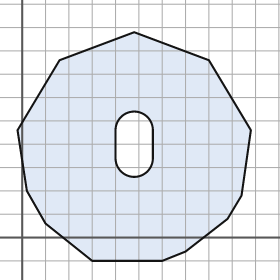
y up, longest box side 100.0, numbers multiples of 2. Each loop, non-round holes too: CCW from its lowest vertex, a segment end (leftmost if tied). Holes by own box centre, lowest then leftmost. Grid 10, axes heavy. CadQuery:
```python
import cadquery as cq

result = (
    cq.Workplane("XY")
    .moveTo(30.0, -10.0)
    .lineTo(60.0, -10.0)
    .lineTo(70.0, -6.0)
    .lineTo(88.0, 8.0)
    .lineTo(94.0, 18.0)
    .lineTo(98.0, 46.0)
    .lineTo(80.0, 76.0)
    .lineTo(48.0, 88.0)
    .lineTo(16.0, 76.0)
    .lineTo(-2.0, 46.0)
    .lineTo(2.0, 20.0)
    .lineTo(10.0, 6.0)
    .close()
    .moveTo(40.0, 34.0)
    .threePointArc((48.0, 26.0), (56.0, 34.0))
    .lineTo(56.0, 46.0)
    .threePointArc((48.0, 54.0), (40.0, 46.0))
    .close()
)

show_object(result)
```